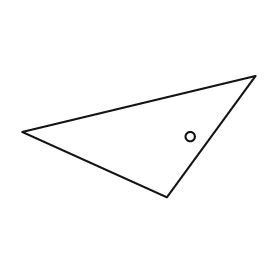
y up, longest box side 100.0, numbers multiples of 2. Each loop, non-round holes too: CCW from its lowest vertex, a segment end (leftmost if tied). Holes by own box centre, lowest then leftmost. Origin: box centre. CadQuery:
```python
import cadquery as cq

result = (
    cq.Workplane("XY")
    .moveTo(12.0, -26.0)
    .lineTo(50.0, 26.0)
    .lineTo(-50.0, 2.0)
    .close()
    .moveTo(22.0, 0.0)
    .circle(2.0)
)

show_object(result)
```